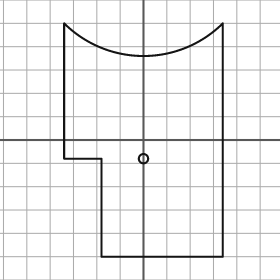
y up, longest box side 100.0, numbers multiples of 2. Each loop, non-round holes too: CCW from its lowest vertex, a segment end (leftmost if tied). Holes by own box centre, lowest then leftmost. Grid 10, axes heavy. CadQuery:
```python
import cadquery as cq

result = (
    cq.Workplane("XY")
    .moveTo(-18.0, -50.0)
    .lineTo(34.0, -50.0)
    .lineTo(34.0, 50.0)
    .threePointArc((0.0, 36.0), (-34.0, 50.0))
    .lineTo(-34.0, -8.0)
    .lineTo(-18.0, -8.0)
    .close()
    .moveTo(0.0, -8.0)
    .circle(2.0)
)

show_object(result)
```